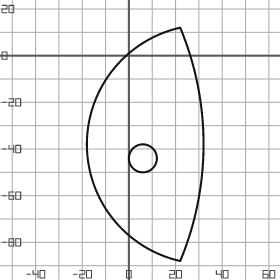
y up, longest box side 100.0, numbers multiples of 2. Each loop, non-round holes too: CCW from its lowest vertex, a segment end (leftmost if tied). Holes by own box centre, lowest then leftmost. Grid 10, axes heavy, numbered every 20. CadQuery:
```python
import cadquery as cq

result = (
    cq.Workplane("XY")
    .moveTo(22.0, -88.0)
    .threePointArc((32.0, -38.0), (22.0, 12.0))
    .threePointArc((-18.0, -38.0), (22.0, -88.0))
    .close()
    .moveTo(6.0, -44.0)
    .circle(6.0)
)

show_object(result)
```